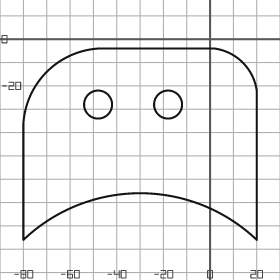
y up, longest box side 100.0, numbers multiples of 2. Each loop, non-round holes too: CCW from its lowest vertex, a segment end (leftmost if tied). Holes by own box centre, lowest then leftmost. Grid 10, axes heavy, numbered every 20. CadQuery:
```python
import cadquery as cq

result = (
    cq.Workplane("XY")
    .moveTo(-80.0, -86.0)
    .threePointArc((-30.0, -66.0), (20.0, -86.0))
    .lineTo(20.0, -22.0)
    .threePointArc((14.0, -10.0), (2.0, -4.0))
    .lineTo(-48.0, -4.0)
    .threePointArc((-70.0, -14.0), (-80.0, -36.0))
    .close()
    .moveTo(-48.0, -28.0)
    .circle(6.0)
    .moveTo(-18.0, -28.0)
    .circle(6.0)
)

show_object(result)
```